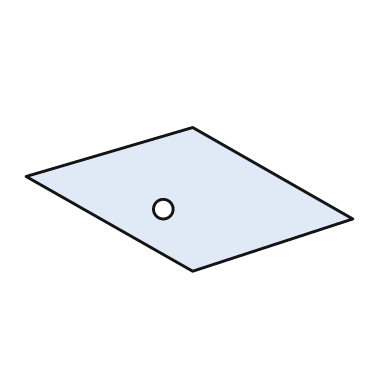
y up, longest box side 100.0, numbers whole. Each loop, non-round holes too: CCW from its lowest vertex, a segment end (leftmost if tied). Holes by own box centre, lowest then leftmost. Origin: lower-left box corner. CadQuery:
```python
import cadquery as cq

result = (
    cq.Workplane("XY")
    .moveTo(51.0, 0.0)
    .lineTo(100.0, 16.0)
    .lineTo(51.0, 44.0)
    .lineTo(0.0, 29.0)
    .close()
    .moveTo(42.0, 19.0)
    .circle(3.0)
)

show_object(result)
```